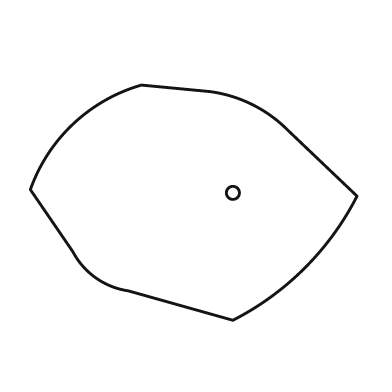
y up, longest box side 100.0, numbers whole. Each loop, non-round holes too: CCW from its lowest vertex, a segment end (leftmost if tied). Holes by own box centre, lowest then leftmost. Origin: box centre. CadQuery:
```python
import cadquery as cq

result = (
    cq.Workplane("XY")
    .moveTo(12.0, -36.0)
    .threePointArc((34.0, -20.0), (50.0, 2.0))
    .lineTo(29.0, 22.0)
    .threePointArc((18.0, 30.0), (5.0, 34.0))
    .lineTo(-16.0, 36.0)
    .threePointArc((-37.0, 24.0), (-50.0, 4.0))
    .lineTo(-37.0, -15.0)
    .threePointArc((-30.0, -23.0), (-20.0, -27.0))
    .close()
    .moveTo(12.0, 3.0)
    .circle(2.0)
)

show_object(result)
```